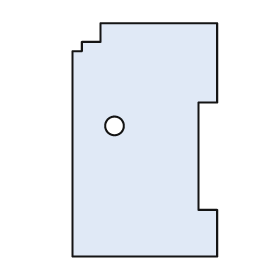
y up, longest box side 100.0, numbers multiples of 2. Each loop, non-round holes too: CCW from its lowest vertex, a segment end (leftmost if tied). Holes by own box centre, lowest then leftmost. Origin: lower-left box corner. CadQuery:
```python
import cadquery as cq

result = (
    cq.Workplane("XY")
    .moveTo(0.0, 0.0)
    .lineTo(62.0, 0.0)
    .lineTo(62.0, 20.0)
    .lineTo(54.0, 20.0)
    .lineTo(54.0, 66.0)
    .lineTo(62.0, 66.0)
    .lineTo(62.0, 100.0)
    .lineTo(12.0, 100.0)
    .lineTo(12.0, 92.0)
    .lineTo(4.0, 92.0)
    .lineTo(4.0, 88.0)
    .lineTo(0.0, 88.0)
    .close()
    .moveTo(18.0, 56.0)
    .circle(4.0)
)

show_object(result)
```